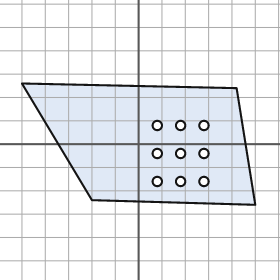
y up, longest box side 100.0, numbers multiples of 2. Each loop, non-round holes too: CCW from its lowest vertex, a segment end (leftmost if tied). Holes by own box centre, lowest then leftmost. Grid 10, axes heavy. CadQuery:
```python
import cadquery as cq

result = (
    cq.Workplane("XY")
    .moveTo(50.0, -26.0)
    .lineTo(42.0, 24.0)
    .lineTo(-50.0, 26.0)
    .lineTo(-20.0, -24.0)
    .close()
    .moveTo(8.0, -16.0)
    .circle(2.0)
    .moveTo(18.0, -16.0)
    .circle(2.0)
    .moveTo(28.0, -16.0)
    .circle(2.0)
    .moveTo(8.0, -4.0)
    .circle(2.0)
    .moveTo(18.0, -4.0)
    .circle(2.0)
    .moveTo(28.0, -4.0)
    .circle(2.0)
    .moveTo(8.0, 8.0)
    .circle(2.0)
    .moveTo(18.0, 8.0)
    .circle(2.0)
    .moveTo(28.0, 8.0)
    .circle(2.0)
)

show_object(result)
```